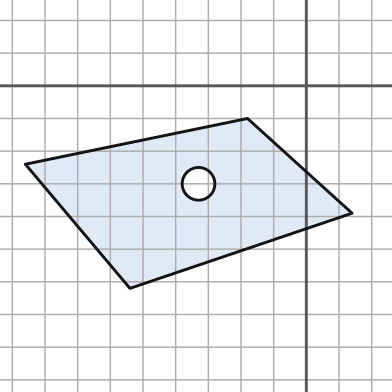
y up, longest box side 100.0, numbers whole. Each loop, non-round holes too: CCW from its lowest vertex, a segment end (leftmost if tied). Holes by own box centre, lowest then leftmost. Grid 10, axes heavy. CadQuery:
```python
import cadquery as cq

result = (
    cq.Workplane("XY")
    .moveTo(-54.0, -62.0)
    .lineTo(14.0, -39.0)
    .lineTo(-18.0, -10.0)
    .lineTo(-86.0, -24.0)
    .close()
    .moveTo(-33.0, -30.0)
    .circle(5.0)
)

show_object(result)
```